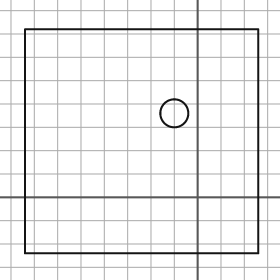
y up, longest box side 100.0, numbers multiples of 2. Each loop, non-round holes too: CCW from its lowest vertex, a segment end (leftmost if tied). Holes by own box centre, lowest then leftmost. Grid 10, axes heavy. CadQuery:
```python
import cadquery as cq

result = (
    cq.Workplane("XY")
    .moveTo(-74.0, -24.0)
    .lineTo(26.0, -24.0)
    .lineTo(26.0, 72.0)
    .lineTo(-74.0, 72.0)
    .close()
    .moveTo(-10.0, 36.0)
    .circle(6.0)
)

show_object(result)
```